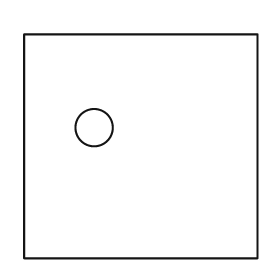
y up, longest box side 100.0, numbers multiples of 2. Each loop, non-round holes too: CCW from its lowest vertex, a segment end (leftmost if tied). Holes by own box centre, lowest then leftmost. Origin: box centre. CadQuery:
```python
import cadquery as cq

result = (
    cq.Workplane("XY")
    .moveTo(-50.0, -48.0)
    .lineTo(50.0, -48.0)
    .lineTo(50.0, 48.0)
    .lineTo(-50.0, 48.0)
    .close()
    .moveTo(-20.0, 8.0)
    .circle(8.0)
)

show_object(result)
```